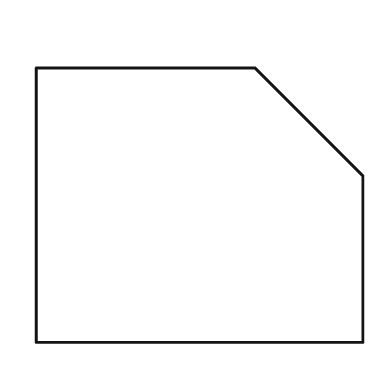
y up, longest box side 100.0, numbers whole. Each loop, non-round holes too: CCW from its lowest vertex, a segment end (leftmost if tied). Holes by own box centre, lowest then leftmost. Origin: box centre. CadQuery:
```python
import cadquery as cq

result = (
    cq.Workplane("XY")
    .moveTo(-50.0, -42.0)
    .lineTo(50.0, -42.0)
    .lineTo(50.0, 9.0)
    .lineTo(17.0, 42.0)
    .lineTo(-50.0, 42.0)
    .close()
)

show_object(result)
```